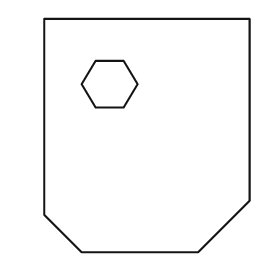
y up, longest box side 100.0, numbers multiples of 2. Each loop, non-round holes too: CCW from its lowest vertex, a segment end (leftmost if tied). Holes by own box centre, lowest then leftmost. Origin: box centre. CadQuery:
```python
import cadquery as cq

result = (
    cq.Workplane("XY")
    .moveTo(-28.0, -50.0)
    .lineTo(22.0, -50.0)
    .lineTo(44.0, -28.0)
    .lineTo(44.0, 50.0)
    .lineTo(-44.0, 50.0)
    .lineTo(-44.0, -34.0)
    .close()
    .moveTo(-22.0, 12.0)
    .lineTo(-10.0, 12.0)
    .lineTo(-4.0, 22.0)
    .lineTo(-10.0, 32.0)
    .lineTo(-22.0, 32.0)
    .lineTo(-28.0, 22.0)
    .close()
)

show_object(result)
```